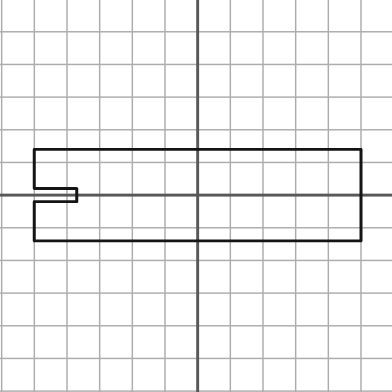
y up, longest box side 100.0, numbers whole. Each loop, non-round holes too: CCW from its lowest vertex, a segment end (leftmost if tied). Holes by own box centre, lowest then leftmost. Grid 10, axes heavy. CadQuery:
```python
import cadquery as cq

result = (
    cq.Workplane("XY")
    .moveTo(-50.0, -14.0)
    .lineTo(50.0, -14.0)
    .lineTo(50.0, 14.0)
    .lineTo(-50.0, 14.0)
    .lineTo(-50.0, 2.0)
    .lineTo(-37.0, 2.0)
    .lineTo(-37.0, -2.0)
    .lineTo(-50.0, -2.0)
    .close()
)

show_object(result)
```